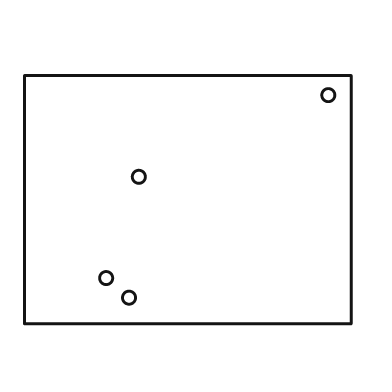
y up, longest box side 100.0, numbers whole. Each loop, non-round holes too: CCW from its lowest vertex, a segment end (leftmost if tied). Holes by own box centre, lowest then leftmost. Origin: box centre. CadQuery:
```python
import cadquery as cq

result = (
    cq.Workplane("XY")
    .moveTo(-50.0, -38.0)
    .lineTo(50.0, -38.0)
    .lineTo(50.0, 38.0)
    .lineTo(-50.0, 38.0)
    .close()
    .moveTo(-18.0, -30.0)
    .circle(2.0)
    .moveTo(-25.0, -24.0)
    .circle(2.0)
    .moveTo(-15.0, 7.0)
    .circle(2.0)
    .moveTo(43.0, 32.0)
    .circle(2.0)
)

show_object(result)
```